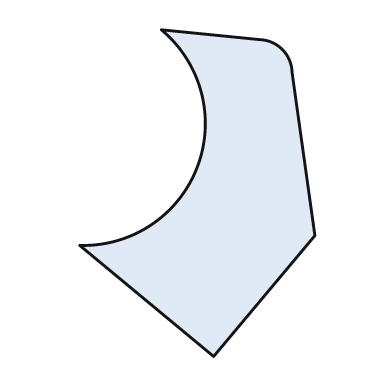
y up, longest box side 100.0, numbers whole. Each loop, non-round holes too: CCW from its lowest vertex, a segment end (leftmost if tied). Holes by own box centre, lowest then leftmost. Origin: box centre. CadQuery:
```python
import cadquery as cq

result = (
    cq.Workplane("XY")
    .moveTo(5.0, -50.0)
    .lineTo(36.0, -13.0)
    .lineTo(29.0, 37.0)
    .threePointArc((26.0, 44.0), (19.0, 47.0))
    .lineTo(-11.0, 50.0)
    .threePointArc((0.0, 8.0), (-36.0, -16.0))
    .close()
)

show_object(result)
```